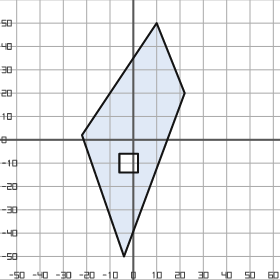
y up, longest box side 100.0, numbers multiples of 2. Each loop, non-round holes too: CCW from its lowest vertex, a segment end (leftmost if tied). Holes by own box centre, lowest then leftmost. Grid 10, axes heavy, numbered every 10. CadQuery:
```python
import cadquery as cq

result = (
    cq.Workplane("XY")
    .moveTo(-4.0, -50.0)
    .lineTo(22.0, 20.0)
    .lineTo(10.0, 50.0)
    .lineTo(-22.0, 2.0)
    .close()
    .moveTo(-6.0, -14.0)
    .lineTo(2.0, -14.0)
    .lineTo(2.0, -6.0)
    .lineTo(-6.0, -6.0)
    .close()
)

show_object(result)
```